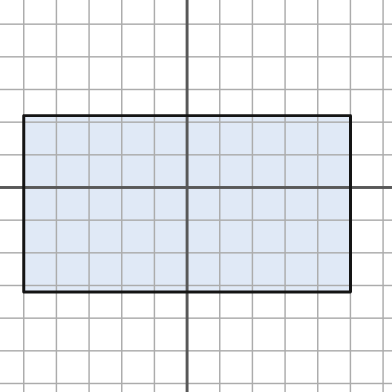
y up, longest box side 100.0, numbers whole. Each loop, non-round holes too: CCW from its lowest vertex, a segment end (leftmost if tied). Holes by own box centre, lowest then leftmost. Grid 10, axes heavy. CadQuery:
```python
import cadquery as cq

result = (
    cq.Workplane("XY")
    .moveTo(-50.0, -32.0)
    .lineTo(50.0, -32.0)
    .lineTo(50.0, 22.0)
    .lineTo(-50.0, 22.0)
    .close()
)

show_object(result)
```